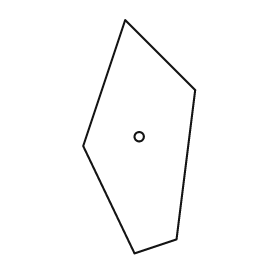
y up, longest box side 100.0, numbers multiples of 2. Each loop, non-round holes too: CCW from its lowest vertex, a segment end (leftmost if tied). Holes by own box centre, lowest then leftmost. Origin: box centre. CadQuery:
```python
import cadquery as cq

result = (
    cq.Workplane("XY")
    .moveTo(-2.0, -50.0)
    .lineTo(16.0, -44.0)
    .lineTo(24.0, 20.0)
    .lineTo(-6.0, 50.0)
    .lineTo(-24.0, -4.0)
    .close()
    .moveTo(0.0, 0.0)
    .circle(2.0)
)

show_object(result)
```